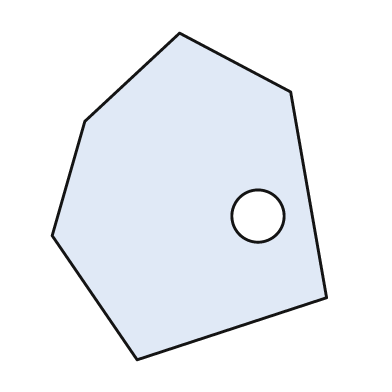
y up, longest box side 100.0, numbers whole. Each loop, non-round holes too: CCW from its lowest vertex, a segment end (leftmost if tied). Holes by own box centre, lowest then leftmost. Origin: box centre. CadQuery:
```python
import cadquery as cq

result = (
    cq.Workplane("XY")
    .moveTo(-16.0, -50.0)
    .lineTo(42.0, -31.0)
    .lineTo(31.0, 32.0)
    .lineTo(-3.0, 50.0)
    .lineTo(-32.0, 23.0)
    .lineTo(-42.0, -12.0)
    .close()
    .moveTo(21.0, -6.0)
    .circle(8.0)
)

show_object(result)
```